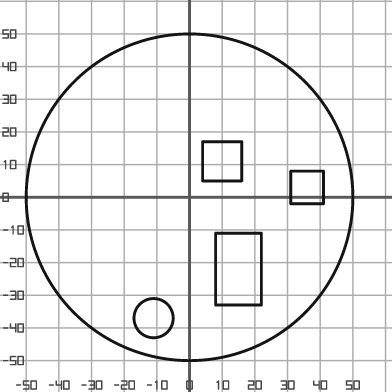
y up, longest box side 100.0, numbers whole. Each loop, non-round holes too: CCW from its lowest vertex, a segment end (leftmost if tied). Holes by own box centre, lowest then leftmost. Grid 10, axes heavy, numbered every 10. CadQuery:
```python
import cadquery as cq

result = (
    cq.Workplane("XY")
    .moveTo(0.0, 0.0)
    .circle(50.0)
    .moveTo(-11.0, -37.0)
    .circle(6.0)
    .moveTo(8.0, -33.0)
    .lineTo(22.0, -33.0)
    .lineTo(22.0, -11.0)
    .lineTo(8.0, -11.0)
    .close()
    .moveTo(31.0, -2.0)
    .lineTo(41.0, -2.0)
    .lineTo(41.0, 8.0)
    .lineTo(31.0, 8.0)
    .close()
    .moveTo(4.0, 5.0)
    .lineTo(16.0, 5.0)
    .lineTo(16.0, 17.0)
    .lineTo(4.0, 17.0)
    .close()
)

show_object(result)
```